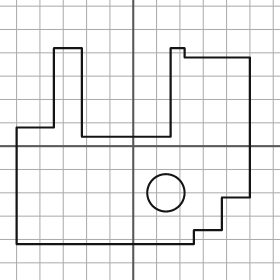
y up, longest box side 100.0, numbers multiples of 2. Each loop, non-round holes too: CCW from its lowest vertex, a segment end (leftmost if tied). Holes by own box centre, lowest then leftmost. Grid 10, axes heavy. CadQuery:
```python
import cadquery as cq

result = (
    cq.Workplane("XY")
    .moveTo(-50.0, -42.0)
    .lineTo(26.0, -42.0)
    .lineTo(26.0, -36.0)
    .lineTo(38.0, -36.0)
    .lineTo(38.0, -22.0)
    .lineTo(50.0, -22.0)
    .lineTo(50.0, 38.0)
    .lineTo(22.0, 38.0)
    .lineTo(22.0, 42.0)
    .lineTo(16.0, 42.0)
    .lineTo(16.0, 4.0)
    .lineTo(-22.0, 4.0)
    .lineTo(-22.0, 42.0)
    .lineTo(-34.0, 42.0)
    .lineTo(-34.0, 8.0)
    .lineTo(-50.0, 8.0)
    .close()
    .moveTo(14.0, -20.0)
    .circle(8.0)
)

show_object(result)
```